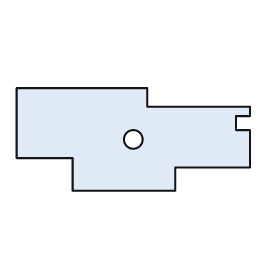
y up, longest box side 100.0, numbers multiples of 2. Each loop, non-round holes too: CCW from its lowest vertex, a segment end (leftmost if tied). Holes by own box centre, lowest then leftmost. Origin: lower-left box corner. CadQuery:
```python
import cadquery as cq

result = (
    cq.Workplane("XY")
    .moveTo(24.0, 0.0)
    .lineTo(68.0, 0.0)
    .lineTo(68.0, 10.0)
    .lineTo(100.0, 10.0)
    .lineTo(100.0, 26.0)
    .lineTo(94.0, 26.0)
    .lineTo(94.0, 32.0)
    .lineTo(100.0, 32.0)
    .lineTo(100.0, 36.0)
    .lineTo(56.0, 36.0)
    .lineTo(56.0, 44.0)
    .lineTo(0.0, 44.0)
    .lineTo(0.0, 14.0)
    .lineTo(24.0, 14.0)
    .close()
    .moveTo(50.0, 22.0)
    .circle(4.0)
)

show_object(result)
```